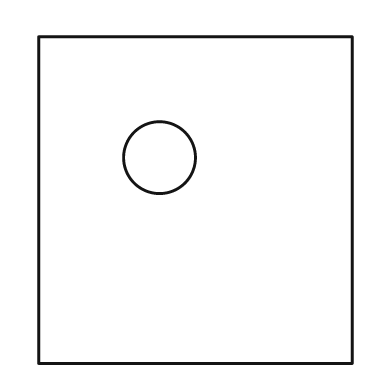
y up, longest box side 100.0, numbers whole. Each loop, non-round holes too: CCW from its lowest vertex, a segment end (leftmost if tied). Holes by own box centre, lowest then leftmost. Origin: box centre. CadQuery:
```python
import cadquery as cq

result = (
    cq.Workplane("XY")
    .moveTo(-48.0, -50.0)
    .lineTo(48.0, -50.0)
    .lineTo(48.0, 50.0)
    .lineTo(-48.0, 50.0)
    .close()
    .moveTo(-11.0, 13.0)
    .circle(11.0)
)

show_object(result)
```